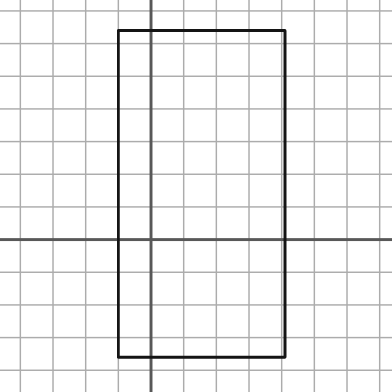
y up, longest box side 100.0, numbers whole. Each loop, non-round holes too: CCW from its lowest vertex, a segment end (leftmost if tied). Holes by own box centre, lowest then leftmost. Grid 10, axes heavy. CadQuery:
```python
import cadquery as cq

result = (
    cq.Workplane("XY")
    .moveTo(-10.0, -36.0)
    .lineTo(41.0, -36.0)
    .lineTo(41.0, 64.0)
    .lineTo(-10.0, 64.0)
    .close()
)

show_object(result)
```